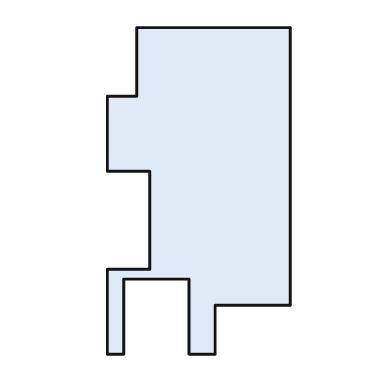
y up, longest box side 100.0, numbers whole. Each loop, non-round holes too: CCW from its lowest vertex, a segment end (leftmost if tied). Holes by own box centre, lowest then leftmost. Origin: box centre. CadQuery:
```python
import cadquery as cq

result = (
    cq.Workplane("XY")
    .moveTo(-28.0, -50.0)
    .lineTo(-23.0, -50.0)
    .lineTo(-23.0, -27.0)
    .lineTo(-3.0, -27.0)
    .lineTo(-3.0, -50.0)
    .lineTo(5.0, -50.0)
    .lineTo(5.0, -35.0)
    .lineTo(28.0, -35.0)
    .lineTo(28.0, 50.0)
    .lineTo(-19.0, 50.0)
    .lineTo(-19.0, 29.0)
    .lineTo(-28.0, 29.0)
    .lineTo(-28.0, 6.0)
    .lineTo(-15.0, 6.0)
    .lineTo(-15.0, -24.0)
    .lineTo(-28.0, -24.0)
    .close()
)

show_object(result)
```